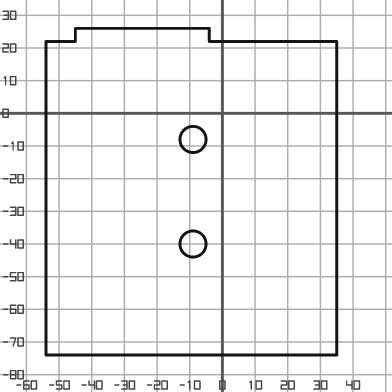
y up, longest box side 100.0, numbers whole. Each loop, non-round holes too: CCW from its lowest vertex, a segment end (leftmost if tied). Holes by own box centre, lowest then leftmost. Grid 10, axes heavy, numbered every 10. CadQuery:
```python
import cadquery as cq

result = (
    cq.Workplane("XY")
    .moveTo(-54.0, -74.0)
    .lineTo(35.0, -74.0)
    .lineTo(35.0, 22.0)
    .lineTo(-4.0, 22.0)
    .lineTo(-4.0, 26.0)
    .lineTo(-45.0, 26.0)
    .lineTo(-45.0, 22.0)
    .lineTo(-54.0, 22.0)
    .close()
    .moveTo(-9.0, -40.0)
    .circle(4.0)
    .moveTo(-9.0, -8.0)
    .circle(4.0)
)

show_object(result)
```